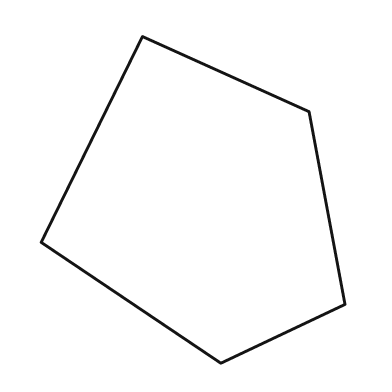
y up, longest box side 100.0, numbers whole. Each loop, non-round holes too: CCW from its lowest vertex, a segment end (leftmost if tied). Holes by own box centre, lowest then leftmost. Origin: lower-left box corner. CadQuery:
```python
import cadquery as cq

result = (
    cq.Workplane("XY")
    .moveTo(55.0, 0.0)
    .lineTo(93.0, 18.0)
    .lineTo(82.0, 77.0)
    .lineTo(31.0, 100.0)
    .lineTo(0.0, 37.0)
    .close()
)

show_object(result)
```